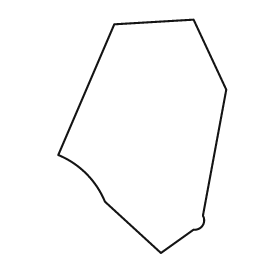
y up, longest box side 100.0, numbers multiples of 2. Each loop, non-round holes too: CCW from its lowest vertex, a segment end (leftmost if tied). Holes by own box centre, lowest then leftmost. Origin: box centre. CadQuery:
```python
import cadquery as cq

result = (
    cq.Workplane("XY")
    .moveTo(8.0, -50.0)
    .lineTo(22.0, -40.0)
    .threePointArc((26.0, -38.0), (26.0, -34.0))
    .lineTo(36.0, 20.0)
    .lineTo(22.0, 50.0)
    .lineTo(-12.0, 48.0)
    .lineTo(-36.0, -8.0)
    .threePointArc((-24.0, -16.0), (-16.0, -28.0))
    .close()
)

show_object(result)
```